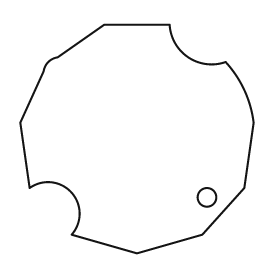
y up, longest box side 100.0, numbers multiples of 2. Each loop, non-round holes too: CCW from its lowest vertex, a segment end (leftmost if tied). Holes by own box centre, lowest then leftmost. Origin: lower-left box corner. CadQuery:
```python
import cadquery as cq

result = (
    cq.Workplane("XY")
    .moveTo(50.0, 0.0)
    .lineTo(78.0, 8.0)
    .lineTo(96.0, 28.0)
    .lineTo(100.0, 56.0)
    .threePointArc((96.0, 70.0), (88.0, 82.0))
    .threePointArc((72.0, 84.0), (64.0, 98.0))
    .lineTo(36.0, 98.0)
    .lineTo(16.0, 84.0)
    .threePointArc((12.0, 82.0), (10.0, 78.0))
    .lineTo(0.0, 56.0)
    .lineTo(4.0, 28.0)
    .threePointArc((22.0, 26.0), (22.0, 8.0))
    .close()
    .moveTo(80.0, 24.0)
    .circle(4.0)
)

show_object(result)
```